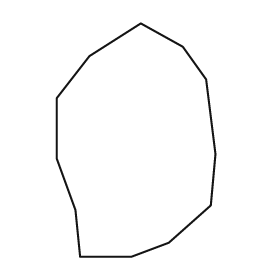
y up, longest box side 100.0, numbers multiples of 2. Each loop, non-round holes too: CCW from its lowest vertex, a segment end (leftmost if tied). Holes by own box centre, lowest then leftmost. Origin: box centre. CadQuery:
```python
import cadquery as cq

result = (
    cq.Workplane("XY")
    .moveTo(-24.0, -50.0)
    .lineTo(-2.0, -50.0)
    .lineTo(14.0, -44.0)
    .lineTo(32.0, -28.0)
    .lineTo(34.0, -6.0)
    .lineTo(30.0, 26.0)
    .lineTo(20.0, 40.0)
    .lineTo(2.0, 50.0)
    .lineTo(-20.0, 36.0)
    .lineTo(-34.0, 18.0)
    .lineTo(-34.0, -8.0)
    .lineTo(-26.0, -30.0)
    .close()
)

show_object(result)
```